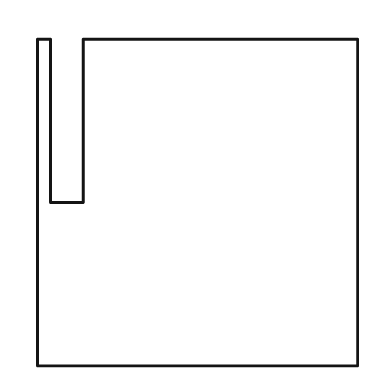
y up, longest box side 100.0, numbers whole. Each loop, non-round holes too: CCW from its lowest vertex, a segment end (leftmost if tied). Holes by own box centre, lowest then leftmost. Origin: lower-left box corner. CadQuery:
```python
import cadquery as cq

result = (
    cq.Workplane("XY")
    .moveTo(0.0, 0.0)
    .lineTo(98.0, 0.0)
    .lineTo(98.0, 100.0)
    .lineTo(14.0, 100.0)
    .lineTo(14.0, 50.0)
    .lineTo(4.0, 50.0)
    .lineTo(4.0, 100.0)
    .lineTo(0.0, 100.0)
    .close()
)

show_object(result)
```